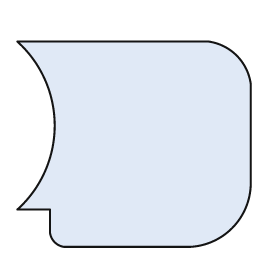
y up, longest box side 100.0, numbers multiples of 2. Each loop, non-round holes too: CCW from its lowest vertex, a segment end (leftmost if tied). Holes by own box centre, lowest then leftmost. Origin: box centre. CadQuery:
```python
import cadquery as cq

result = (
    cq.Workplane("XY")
    .moveTo(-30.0, -44.0)
    .lineTo(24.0, -44.0)
    .threePointArc((42.0, -36.0), (50.0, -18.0))
    .lineTo(50.0, 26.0)
    .threePointArc((44.0, 38.0), (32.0, 44.0))
    .lineTo(-50.0, 44.0)
    .threePointArc((-34.0, 8.0), (-50.0, -28.0))
    .lineTo(-36.0, -28.0)
    .lineTo(-36.0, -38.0)
    .threePointArc((-34.0, -42.0), (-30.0, -44.0))
    .close()
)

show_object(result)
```